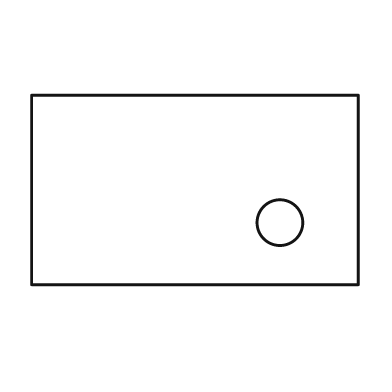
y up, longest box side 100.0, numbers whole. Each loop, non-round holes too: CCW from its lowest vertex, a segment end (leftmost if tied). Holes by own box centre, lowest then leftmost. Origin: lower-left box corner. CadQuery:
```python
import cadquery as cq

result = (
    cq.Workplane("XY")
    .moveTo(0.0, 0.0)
    .lineTo(100.0, 0.0)
    .lineTo(100.0, 58.0)
    .lineTo(0.0, 58.0)
    .close()
    .moveTo(76.0, 19.0)
    .circle(7.0)
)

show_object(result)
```